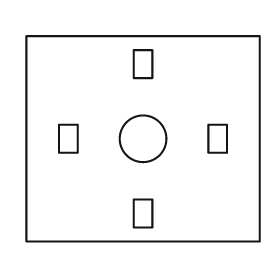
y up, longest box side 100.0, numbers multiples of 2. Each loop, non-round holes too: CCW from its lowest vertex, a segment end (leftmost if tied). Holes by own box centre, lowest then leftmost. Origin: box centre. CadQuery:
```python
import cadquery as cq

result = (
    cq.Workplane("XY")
    .moveTo(-50.0, -44.0)
    .lineTo(50.0, -44.0)
    .lineTo(50.0, 44.0)
    .lineTo(-50.0, 44.0)
    .close()
    .moveTo(-4.0, -38.0)
    .lineTo(4.0, -38.0)
    .lineTo(4.0, -26.0)
    .lineTo(-4.0, -26.0)
    .close()
    .moveTo(-36.0, -6.0)
    .lineTo(-28.0, -6.0)
    .lineTo(-28.0, 6.0)
    .lineTo(-36.0, 6.0)
    .close()
    .moveTo(0.0, 0.0)
    .circle(10.0)
    .moveTo(28.0, -6.0)
    .lineTo(36.0, -6.0)
    .lineTo(36.0, 6.0)
    .lineTo(28.0, 6.0)
    .close()
    .moveTo(-4.0, 26.0)
    .lineTo(4.0, 26.0)
    .lineTo(4.0, 38.0)
    .lineTo(-4.0, 38.0)
    .close()
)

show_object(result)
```